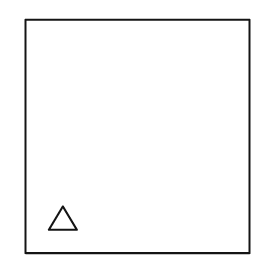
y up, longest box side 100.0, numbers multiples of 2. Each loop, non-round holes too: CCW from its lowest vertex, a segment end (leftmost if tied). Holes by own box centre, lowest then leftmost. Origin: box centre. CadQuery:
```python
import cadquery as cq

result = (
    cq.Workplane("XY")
    .moveTo(-48.0, -50.0)
    .lineTo(48.0, -50.0)
    .lineTo(48.0, 50.0)
    .lineTo(-48.0, 50.0)
    .close()
    .moveTo(-38.0, -40.0)
    .lineTo(-26.0, -40.0)
    .lineTo(-32.0, -30.0)
    .close()
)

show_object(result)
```